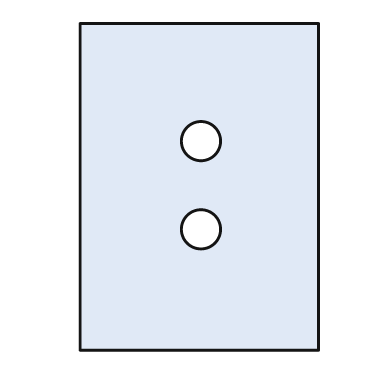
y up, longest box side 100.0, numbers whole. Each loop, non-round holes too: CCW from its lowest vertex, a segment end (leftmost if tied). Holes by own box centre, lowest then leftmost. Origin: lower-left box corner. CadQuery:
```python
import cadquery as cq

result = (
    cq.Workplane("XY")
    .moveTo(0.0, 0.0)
    .lineTo(73.0, 0.0)
    .lineTo(73.0, 100.0)
    .lineTo(0.0, 100.0)
    .close()
    .moveTo(37.0, 37.0)
    .circle(6.0)
    .moveTo(37.0, 64.0)
    .circle(6.0)
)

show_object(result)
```